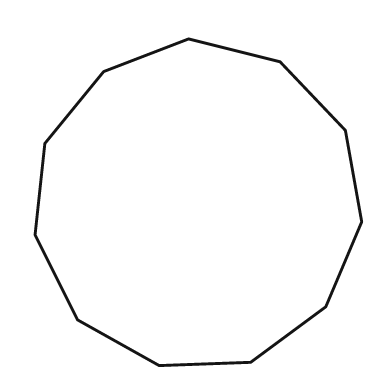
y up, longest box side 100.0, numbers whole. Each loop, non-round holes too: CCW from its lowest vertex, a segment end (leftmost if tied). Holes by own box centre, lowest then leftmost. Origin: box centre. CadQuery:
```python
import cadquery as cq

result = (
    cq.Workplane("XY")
    .moveTo(-12.0, -50.0)
    .lineTo(16.0, -49.0)
    .lineTo(39.0, -32.0)
    .lineTo(50.0, -6.0)
    .lineTo(45.0, 22.0)
    .lineTo(25.0, 43.0)
    .lineTo(-3.0, 50.0)
    .lineTo(-29.0, 40.0)
    .lineTo(-47.0, 18.0)
    .lineTo(-50.0, -10.0)
    .lineTo(-37.0, -36.0)
    .close()
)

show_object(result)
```